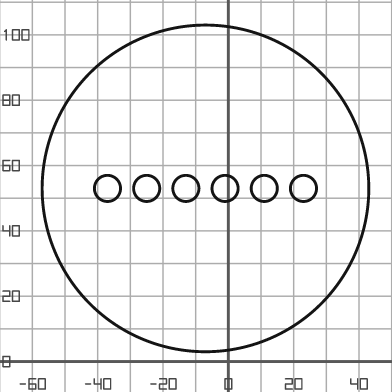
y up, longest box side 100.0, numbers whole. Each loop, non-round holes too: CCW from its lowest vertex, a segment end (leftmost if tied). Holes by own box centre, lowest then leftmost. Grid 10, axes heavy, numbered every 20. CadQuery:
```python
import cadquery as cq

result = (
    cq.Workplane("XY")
    .moveTo(-7.0, 53.0)
    .circle(50.0)
    .moveTo(-37.0, 53.0)
    .circle(4.0)
    .moveTo(-25.0, 53.0)
    .circle(4.0)
    .moveTo(-13.0, 53.0)
    .circle(4.0)
    .moveTo(-1.0, 53.0)
    .circle(4.0)
    .moveTo(11.0, 53.0)
    .circle(4.0)
    .moveTo(23.0, 53.0)
    .circle(4.0)
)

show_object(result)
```